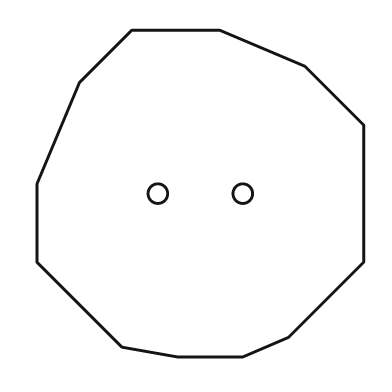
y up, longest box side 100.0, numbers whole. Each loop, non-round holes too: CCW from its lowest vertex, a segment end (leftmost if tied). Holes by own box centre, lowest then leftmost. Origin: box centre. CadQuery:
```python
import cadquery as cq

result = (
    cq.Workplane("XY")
    .moveTo(-7.0, -50.0)
    .lineTo(13.0, -50.0)
    .lineTo(27.0, -44.0)
    .lineTo(50.0, -21.0)
    .lineTo(50.0, 21.0)
    .lineTo(32.0, 39.0)
    .lineTo(6.0, 50.0)
    .lineTo(-21.0, 50.0)
    .lineTo(-37.0, 34.0)
    .lineTo(-50.0, 3.0)
    .lineTo(-50.0, -21.0)
    .lineTo(-24.0, -47.0)
    .close()
    .moveTo(-13.0, 0.0)
    .circle(3.0)
    .moveTo(13.0, 0.0)
    .circle(3.0)
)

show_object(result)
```